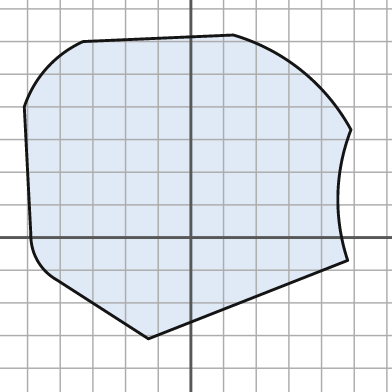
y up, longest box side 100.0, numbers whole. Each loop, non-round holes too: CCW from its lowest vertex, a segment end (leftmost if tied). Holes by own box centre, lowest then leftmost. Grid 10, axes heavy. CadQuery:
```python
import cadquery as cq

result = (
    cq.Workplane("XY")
    .moveTo(-13.0, -31.0)
    .lineTo(48.0, -7.0)
    .threePointArc((45.0, 13.0), (49.0, 33.0))
    .threePointArc((34.0, 51.0), (13.0, 62.0))
    .lineTo(-33.0, 60.0)
    .threePointArc((-44.0, 52.0), (-51.0, 40.0))
    .lineTo(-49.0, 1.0)
    .threePointArc((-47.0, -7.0), (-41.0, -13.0))
    .close()
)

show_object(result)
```